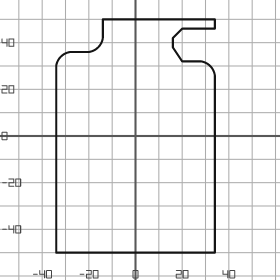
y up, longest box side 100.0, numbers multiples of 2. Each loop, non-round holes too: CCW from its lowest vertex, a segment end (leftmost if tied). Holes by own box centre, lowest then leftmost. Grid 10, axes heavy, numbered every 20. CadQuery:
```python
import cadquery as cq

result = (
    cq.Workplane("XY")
    .moveTo(-34.0, -50.0)
    .lineTo(34.0, -50.0)
    .lineTo(34.0, 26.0)
    .threePointArc((32.0, 30.0), (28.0, 32.0))
    .lineTo(20.0, 32.0)
    .lineTo(16.0, 38.0)
    .lineTo(16.0, 42.0)
    .lineTo(20.0, 46.0)
    .lineTo(34.0, 46.0)
    .lineTo(34.0, 50.0)
    .lineTo(-14.0, 50.0)
    .lineTo(-14.0, 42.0)
    .threePointArc((-16.0, 38.0), (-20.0, 36.0))
    .lineTo(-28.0, 36.0)
    .threePointArc((-32.0, 34.0), (-34.0, 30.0))
    .close()
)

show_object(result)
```